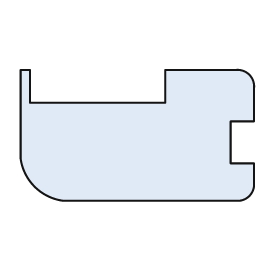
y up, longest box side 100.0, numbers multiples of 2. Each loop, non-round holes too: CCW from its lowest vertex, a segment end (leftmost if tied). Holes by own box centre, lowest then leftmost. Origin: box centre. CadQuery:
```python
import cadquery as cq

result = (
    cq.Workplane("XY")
    .moveTo(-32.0, -28.0)
    .lineTo(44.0, -28.0)
    .threePointArc((48.0, -26.0), (50.0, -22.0))
    .lineTo(50.0, -12.0)
    .lineTo(40.0, -12.0)
    .lineTo(40.0, 6.0)
    .lineTo(50.0, 6.0)
    .lineTo(50.0, 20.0)
    .threePointArc((48.0, 26.0), (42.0, 28.0))
    .lineTo(12.0, 28.0)
    .lineTo(12.0, 14.0)
    .lineTo(-46.0, 14.0)
    .lineTo(-46.0, 28.0)
    .lineTo(-50.0, 28.0)
    .lineTo(-50.0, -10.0)
    .threePointArc((-44.0, -22.0), (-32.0, -28.0))
    .close()
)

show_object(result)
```